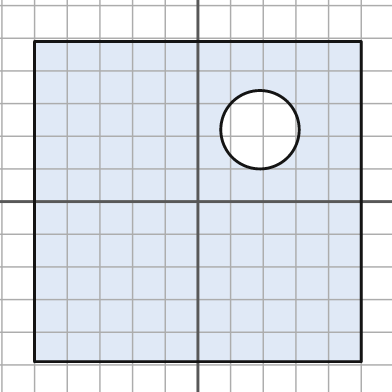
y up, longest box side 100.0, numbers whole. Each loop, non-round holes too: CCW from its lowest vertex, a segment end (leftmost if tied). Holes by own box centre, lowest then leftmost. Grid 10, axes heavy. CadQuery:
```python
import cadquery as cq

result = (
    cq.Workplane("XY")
    .moveTo(-50.0, -49.0)
    .lineTo(50.0, -49.0)
    .lineTo(50.0, 49.0)
    .lineTo(-50.0, 49.0)
    .close()
    .moveTo(19.0, 22.0)
    .circle(12.0)
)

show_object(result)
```